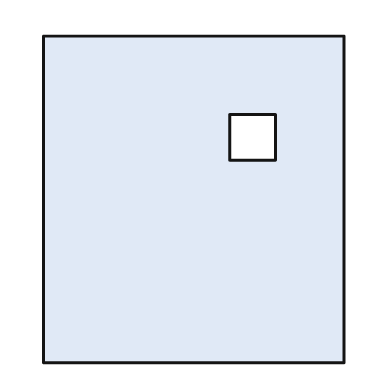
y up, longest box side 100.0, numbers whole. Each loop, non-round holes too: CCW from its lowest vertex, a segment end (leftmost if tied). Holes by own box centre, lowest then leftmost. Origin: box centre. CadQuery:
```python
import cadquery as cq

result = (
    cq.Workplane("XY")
    .moveTo(-46.0, -50.0)
    .lineTo(46.0, -50.0)
    .lineTo(46.0, 50.0)
    .lineTo(-46.0, 50.0)
    .close()
    .moveTo(11.0, 12.0)
    .lineTo(25.0, 12.0)
    .lineTo(25.0, 26.0)
    .lineTo(11.0, 26.0)
    .close()
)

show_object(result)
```